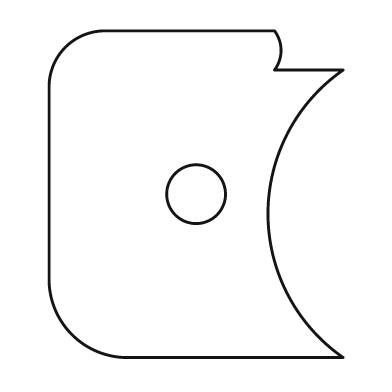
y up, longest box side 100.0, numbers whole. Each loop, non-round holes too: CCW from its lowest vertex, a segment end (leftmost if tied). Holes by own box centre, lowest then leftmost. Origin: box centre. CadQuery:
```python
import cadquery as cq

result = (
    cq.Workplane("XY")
    .moveTo(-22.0, -50.0)
    .lineTo(45.0, -50.0)
    .threePointArc((22.0, -6.0), (45.0, 38.0))
    .lineTo(24.0, 38.0)
    .threePointArc((26.0, 44.0), (24.0, 50.0))
    .lineTo(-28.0, 50.0)
    .threePointArc((-40.0, 45.0), (-45.0, 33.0))
    .lineTo(-45.0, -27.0)
    .threePointArc((-38.0, -43.0), (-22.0, -50.0))
    .close()
    .moveTo(0.0, 0.0)
    .circle(9.0)
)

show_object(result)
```